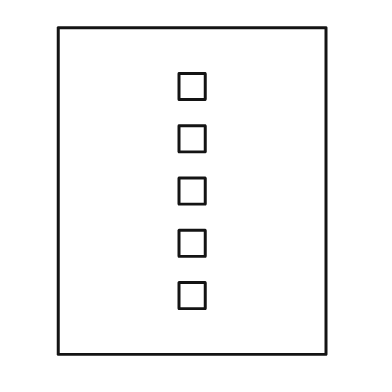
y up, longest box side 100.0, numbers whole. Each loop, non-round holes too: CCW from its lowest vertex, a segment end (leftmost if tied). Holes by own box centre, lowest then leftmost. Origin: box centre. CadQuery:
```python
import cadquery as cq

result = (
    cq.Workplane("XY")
    .moveTo(-41.0, -50.0)
    .lineTo(41.0, -50.0)
    .lineTo(41.0, 50.0)
    .lineTo(-41.0, 50.0)
    .close()
    .moveTo(-4.0, -36.0)
    .lineTo(4.0, -36.0)
    .lineTo(4.0, -28.0)
    .lineTo(-4.0, -28.0)
    .close()
    .moveTo(-4.0, -20.0)
    .lineTo(4.0, -20.0)
    .lineTo(4.0, -12.0)
    .lineTo(-4.0, -12.0)
    .close()
    .moveTo(-4.0, -4.0)
    .lineTo(4.0, -4.0)
    .lineTo(4.0, 4.0)
    .lineTo(-4.0, 4.0)
    .close()
    .moveTo(-4.0, 12.0)
    .lineTo(4.0, 12.0)
    .lineTo(4.0, 20.0)
    .lineTo(-4.0, 20.0)
    .close()
    .moveTo(-4.0, 28.0)
    .lineTo(4.0, 28.0)
    .lineTo(4.0, 36.0)
    .lineTo(-4.0, 36.0)
    .close()
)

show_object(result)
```